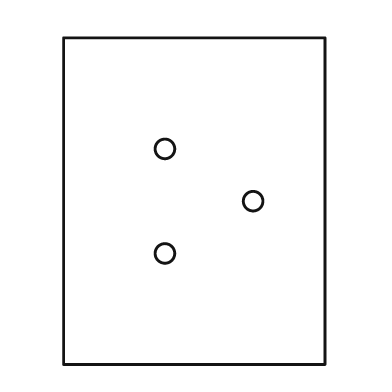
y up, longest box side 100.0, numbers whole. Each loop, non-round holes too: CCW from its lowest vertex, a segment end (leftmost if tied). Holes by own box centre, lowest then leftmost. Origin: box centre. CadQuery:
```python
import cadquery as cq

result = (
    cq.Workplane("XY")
    .moveTo(-40.0, -50.0)
    .lineTo(40.0, -50.0)
    .lineTo(40.0, 50.0)
    .lineTo(-40.0, 50.0)
    .close()
    .moveTo(-9.0, -16.0)
    .circle(3.0)
    .moveTo(18.0, 0.0)
    .circle(3.0)
    .moveTo(-9.0, 16.0)
    .circle(3.0)
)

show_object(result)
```